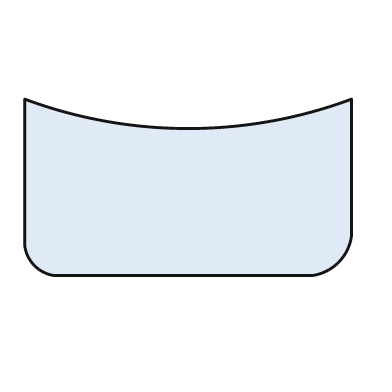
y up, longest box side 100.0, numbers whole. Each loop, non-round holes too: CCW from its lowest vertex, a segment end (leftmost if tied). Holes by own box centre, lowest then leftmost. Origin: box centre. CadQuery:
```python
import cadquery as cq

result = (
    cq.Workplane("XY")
    .moveTo(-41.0, -27.0)
    .lineTo(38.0, -27.0)
    .threePointArc((46.0, -23.0), (50.0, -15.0))
    .lineTo(50.0, 27.0)
    .threePointArc((0.0, 18.0), (-50.0, 27.0))
    .lineTo(-50.0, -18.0)
    .threePointArc((-47.0, -24.0), (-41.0, -27.0))
    .close()
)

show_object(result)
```